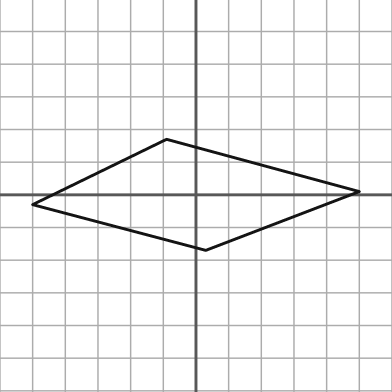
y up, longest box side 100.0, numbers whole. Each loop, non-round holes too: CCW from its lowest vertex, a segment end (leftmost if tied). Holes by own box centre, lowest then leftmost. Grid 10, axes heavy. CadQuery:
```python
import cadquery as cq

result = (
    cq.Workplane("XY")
    .moveTo(3.0, -17.0)
    .lineTo(50.0, 1.0)
    .lineTo(-9.0, 17.0)
    .lineTo(-50.0, -3.0)
    .close()
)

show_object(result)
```